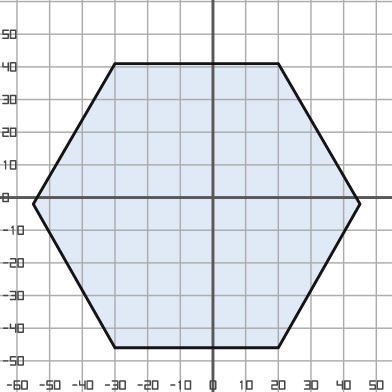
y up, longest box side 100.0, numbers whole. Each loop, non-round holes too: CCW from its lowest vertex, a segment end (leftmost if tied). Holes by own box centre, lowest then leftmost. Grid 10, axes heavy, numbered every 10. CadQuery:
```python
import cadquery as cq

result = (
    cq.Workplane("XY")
    .moveTo(-30.0, -46.0)
    .lineTo(20.0, -46.0)
    .lineTo(45.0, -2.0)
    .lineTo(20.0, 41.0)
    .lineTo(-30.0, 41.0)
    .lineTo(-55.0, -2.0)
    .close()
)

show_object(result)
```